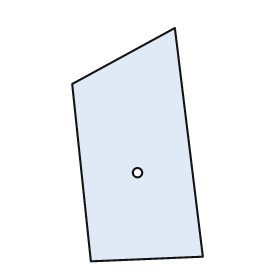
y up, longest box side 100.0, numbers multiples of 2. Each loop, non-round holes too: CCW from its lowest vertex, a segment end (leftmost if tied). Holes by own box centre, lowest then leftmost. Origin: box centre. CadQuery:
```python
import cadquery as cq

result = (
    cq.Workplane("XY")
    .moveTo(-20.0, -50.0)
    .lineTo(28.0, -48.0)
    .lineTo(16.0, 50.0)
    .lineTo(-28.0, 26.0)
    .close()
    .moveTo(0.0, -12.0)
    .circle(2.0)
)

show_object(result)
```